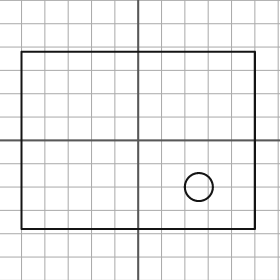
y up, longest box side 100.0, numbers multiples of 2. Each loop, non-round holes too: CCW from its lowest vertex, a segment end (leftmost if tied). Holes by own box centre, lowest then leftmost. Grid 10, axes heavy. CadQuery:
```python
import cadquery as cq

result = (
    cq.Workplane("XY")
    .moveTo(-50.0, -38.0)
    .lineTo(50.0, -38.0)
    .lineTo(50.0, 38.0)
    .lineTo(-50.0, 38.0)
    .close()
    .moveTo(26.0, -20.0)
    .circle(6.0)
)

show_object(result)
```